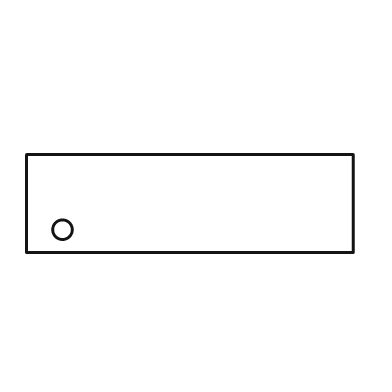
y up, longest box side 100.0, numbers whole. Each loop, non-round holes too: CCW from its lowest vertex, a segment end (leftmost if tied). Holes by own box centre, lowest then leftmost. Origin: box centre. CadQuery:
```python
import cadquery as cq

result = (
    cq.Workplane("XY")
    .moveTo(-50.0, -15.0)
    .lineTo(50.0, -15.0)
    .lineTo(50.0, 15.0)
    .lineTo(-50.0, 15.0)
    .close()
    .moveTo(-39.0, -8.0)
    .circle(3.0)
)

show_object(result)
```